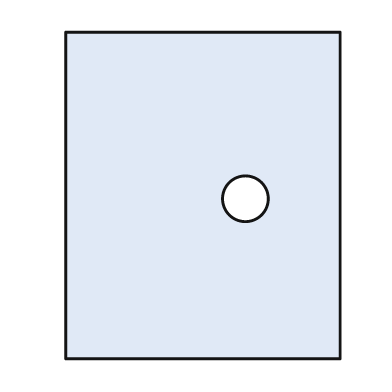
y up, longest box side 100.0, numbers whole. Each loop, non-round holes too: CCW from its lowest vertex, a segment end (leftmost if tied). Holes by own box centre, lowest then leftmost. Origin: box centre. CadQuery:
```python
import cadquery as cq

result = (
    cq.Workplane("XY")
    .moveTo(-42.0, -50.0)
    .lineTo(42.0, -50.0)
    .lineTo(42.0, 50.0)
    .lineTo(-42.0, 50.0)
    .close()
    .moveTo(13.0, -1.0)
    .circle(7.0)
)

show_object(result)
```